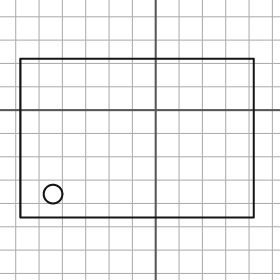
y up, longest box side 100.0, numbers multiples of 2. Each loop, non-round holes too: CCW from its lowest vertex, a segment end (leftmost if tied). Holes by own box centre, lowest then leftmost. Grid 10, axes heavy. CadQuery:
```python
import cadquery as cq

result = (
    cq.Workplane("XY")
    .moveTo(-58.0, -46.0)
    .lineTo(42.0, -46.0)
    .lineTo(42.0, 22.0)
    .lineTo(-58.0, 22.0)
    .close()
    .moveTo(-44.0, -36.0)
    .circle(4.0)
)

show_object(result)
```